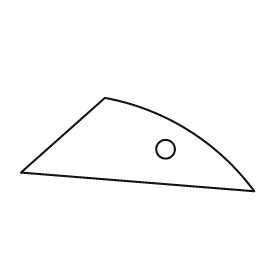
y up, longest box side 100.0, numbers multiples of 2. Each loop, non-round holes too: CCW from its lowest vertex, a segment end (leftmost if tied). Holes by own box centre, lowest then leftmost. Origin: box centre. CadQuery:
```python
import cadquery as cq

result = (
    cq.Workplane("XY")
    .moveTo(50.0, -20.0)
    .threePointArc((22.0, 6.0), (-14.0, 20.0))
    .lineTo(-50.0, -12.0)
    .close()
    .moveTo(12.0, -2.0)
    .circle(4.0)
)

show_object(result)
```